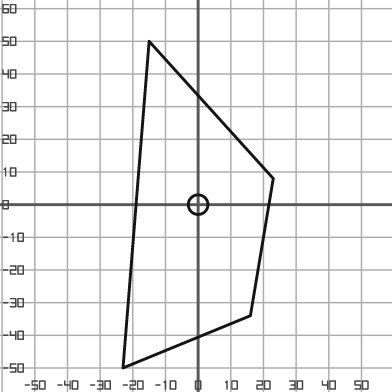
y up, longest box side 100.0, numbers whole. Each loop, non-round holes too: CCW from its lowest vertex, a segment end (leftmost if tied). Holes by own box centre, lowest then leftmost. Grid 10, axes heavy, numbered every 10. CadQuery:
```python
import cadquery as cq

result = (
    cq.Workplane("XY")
    .moveTo(-23.0, -50.0)
    .lineTo(16.0, -34.0)
    .lineTo(23.0, 8.0)
    .lineTo(-15.0, 50.0)
    .close()
    .moveTo(0.0, 0.0)
    .circle(3.0)
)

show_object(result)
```